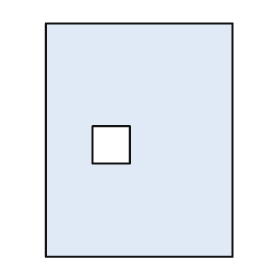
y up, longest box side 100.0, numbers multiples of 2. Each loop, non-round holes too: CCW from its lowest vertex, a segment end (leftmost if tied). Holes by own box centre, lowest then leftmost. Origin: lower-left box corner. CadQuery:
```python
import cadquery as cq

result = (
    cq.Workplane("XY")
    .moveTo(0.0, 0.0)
    .lineTo(80.0, 0.0)
    .lineTo(80.0, 100.0)
    .lineTo(0.0, 100.0)
    .close()
    .moveTo(20.0, 40.0)
    .lineTo(36.0, 40.0)
    .lineTo(36.0, 56.0)
    .lineTo(20.0, 56.0)
    .close()
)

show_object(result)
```